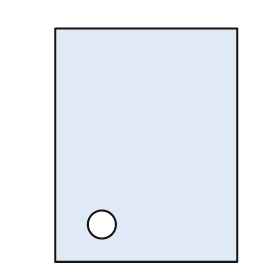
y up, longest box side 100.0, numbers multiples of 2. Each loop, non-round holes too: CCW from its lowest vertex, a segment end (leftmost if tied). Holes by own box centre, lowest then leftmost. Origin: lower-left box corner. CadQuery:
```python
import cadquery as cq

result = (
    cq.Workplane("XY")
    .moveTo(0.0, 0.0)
    .lineTo(78.0, 0.0)
    .lineTo(78.0, 100.0)
    .lineTo(0.0, 100.0)
    .close()
    .moveTo(20.0, 16.0)
    .circle(6.0)
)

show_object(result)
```